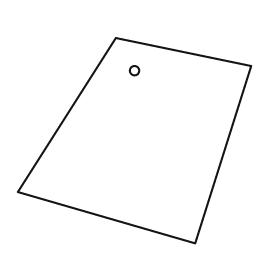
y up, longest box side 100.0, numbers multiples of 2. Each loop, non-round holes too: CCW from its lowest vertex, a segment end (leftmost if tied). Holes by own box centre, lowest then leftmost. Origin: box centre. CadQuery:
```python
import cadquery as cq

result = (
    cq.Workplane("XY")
    .moveTo(26.0, -44.0)
    .lineTo(50.0, 32.0)
    .lineTo(-8.0, 44.0)
    .lineTo(-50.0, -22.0)
    .close()
    .moveTo(0.0, 30.0)
    .circle(2.0)
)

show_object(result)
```